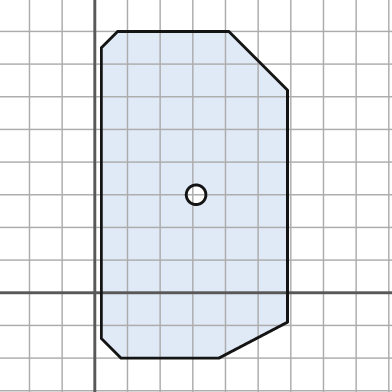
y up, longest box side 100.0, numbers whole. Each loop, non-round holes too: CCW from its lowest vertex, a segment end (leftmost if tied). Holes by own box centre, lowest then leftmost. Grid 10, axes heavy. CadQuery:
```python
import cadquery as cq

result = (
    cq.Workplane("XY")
    .moveTo(8.0, -20.0)
    .lineTo(38.0, -20.0)
    .lineTo(59.0, -9.0)
    .lineTo(59.0, 62.0)
    .lineTo(41.0, 80.0)
    .lineTo(7.0, 80.0)
    .lineTo(2.0, 75.0)
    .lineTo(2.0, -14.0)
    .close()
    .moveTo(31.0, 30.0)
    .circle(3.0)
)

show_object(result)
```